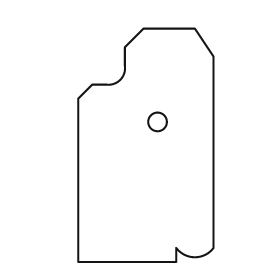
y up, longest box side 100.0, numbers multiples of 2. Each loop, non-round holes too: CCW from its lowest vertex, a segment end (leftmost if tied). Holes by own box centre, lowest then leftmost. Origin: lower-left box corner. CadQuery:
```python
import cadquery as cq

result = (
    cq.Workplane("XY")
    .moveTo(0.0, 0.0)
    .lineTo(42.0, 0.0)
    .lineTo(42.0, 6.0)
    .threePointArc((50.0, 2.0), (58.0, 6.0))
    .lineTo(58.0, 88.0)
    .lineTo(50.0, 100.0)
    .lineTo(28.0, 100.0)
    .lineTo(20.0, 92.0)
    .lineTo(20.0, 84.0)
    .threePointArc((18.0, 78.0), (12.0, 76.0))
    .lineTo(6.0, 76.0)
    .lineTo(0.0, 70.0)
    .close()
    .moveTo(34.0, 60.0)
    .circle(4.0)
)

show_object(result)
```